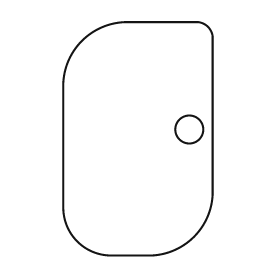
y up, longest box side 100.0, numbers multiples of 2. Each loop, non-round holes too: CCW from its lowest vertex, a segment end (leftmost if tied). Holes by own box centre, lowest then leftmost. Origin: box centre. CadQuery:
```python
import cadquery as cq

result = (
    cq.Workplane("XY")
    .moveTo(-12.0, -50.0)
    .lineTo(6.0, -50.0)
    .threePointArc((24.0, -42.0), (32.0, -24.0))
    .lineTo(32.0, 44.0)
    .threePointArc((30.0, 48.0), (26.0, 50.0))
    .lineTo(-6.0, 50.0)
    .threePointArc((-24.0, 42.0), (-32.0, 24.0))
    .lineTo(-32.0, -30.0)
    .threePointArc((-26.0, -44.0), (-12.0, -50.0))
    .close()
    .moveTo(22.0, 4.0)
    .circle(6.0)
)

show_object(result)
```